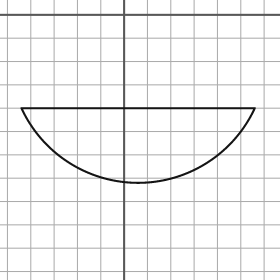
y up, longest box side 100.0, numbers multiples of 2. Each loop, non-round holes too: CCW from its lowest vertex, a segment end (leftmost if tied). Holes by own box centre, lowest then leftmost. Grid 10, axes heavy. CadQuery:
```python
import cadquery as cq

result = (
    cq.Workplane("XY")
    .moveTo(-44.0, -40.0)
    .threePointArc((6.0, -72.0), (56.0, -40.0))
    .close()
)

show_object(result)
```